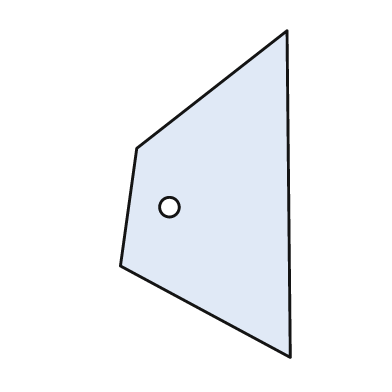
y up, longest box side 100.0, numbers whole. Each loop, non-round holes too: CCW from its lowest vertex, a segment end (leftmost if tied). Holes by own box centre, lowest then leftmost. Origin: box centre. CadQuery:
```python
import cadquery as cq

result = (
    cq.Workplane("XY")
    .moveTo(26.0, -50.0)
    .lineTo(25.0, 50.0)
    .lineTo(-21.0, 14.0)
    .lineTo(-26.0, -22.0)
    .close()
    .moveTo(-11.0, -4.0)
    .circle(3.0)
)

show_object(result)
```